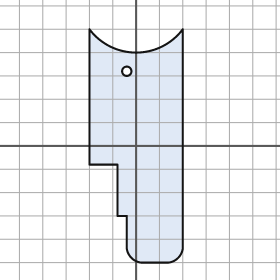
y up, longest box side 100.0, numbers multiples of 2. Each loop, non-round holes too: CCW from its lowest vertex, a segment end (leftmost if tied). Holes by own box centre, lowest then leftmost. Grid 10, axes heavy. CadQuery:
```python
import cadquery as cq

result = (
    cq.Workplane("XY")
    .moveTo(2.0, -50.0)
    .lineTo(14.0, -50.0)
    .threePointArc((18.0, -48.0), (20.0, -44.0))
    .lineTo(20.0, 50.0)
    .threePointArc((0.0, 40.0), (-20.0, 50.0))
    .lineTo(-20.0, -8.0)
    .lineTo(-8.0, -8.0)
    .lineTo(-8.0, -30.0)
    .lineTo(-4.0, -30.0)
    .lineTo(-4.0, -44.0)
    .threePointArc((-2.0, -48.0), (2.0, -50.0))
    .close()
    .moveTo(-4.0, 32.0)
    .circle(2.0)
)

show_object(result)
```